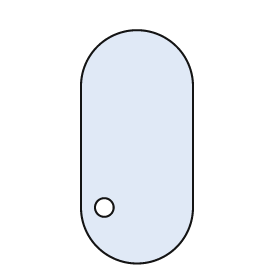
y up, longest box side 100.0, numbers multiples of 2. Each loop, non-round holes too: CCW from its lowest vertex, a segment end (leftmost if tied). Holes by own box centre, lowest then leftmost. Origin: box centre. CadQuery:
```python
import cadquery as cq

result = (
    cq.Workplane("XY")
    .moveTo(-24.0, -26.0)
    .threePointArc((0.0, -50.0), (24.0, -26.0))
    .lineTo(24.0, 26.0)
    .threePointArc((0.0, 50.0), (-24.0, 26.0))
    .close()
    .moveTo(-14.0, -26.0)
    .circle(4.0)
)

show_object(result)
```